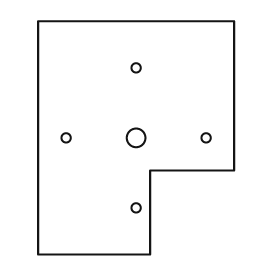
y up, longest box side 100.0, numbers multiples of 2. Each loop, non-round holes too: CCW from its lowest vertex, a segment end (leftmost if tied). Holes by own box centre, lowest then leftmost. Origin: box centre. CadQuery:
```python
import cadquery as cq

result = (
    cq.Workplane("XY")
    .moveTo(-42.0, -50.0)
    .lineTo(6.0, -50.0)
    .lineTo(6.0, -14.0)
    .lineTo(42.0, -14.0)
    .lineTo(42.0, 50.0)
    .lineTo(-42.0, 50.0)
    .close()
    .moveTo(0.0, -30.0)
    .circle(2.0)
    .moveTo(-30.0, 0.0)
    .circle(2.0)
    .moveTo(0.0, 0.0)
    .circle(4.0)
    .moveTo(30.0, 0.0)
    .circle(2.0)
    .moveTo(0.0, 30.0)
    .circle(2.0)
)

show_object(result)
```